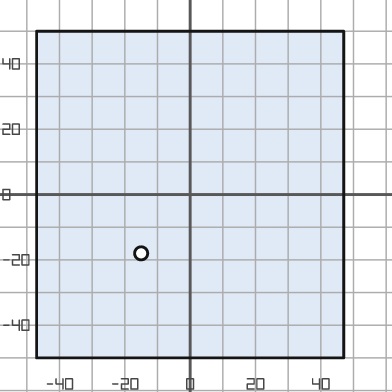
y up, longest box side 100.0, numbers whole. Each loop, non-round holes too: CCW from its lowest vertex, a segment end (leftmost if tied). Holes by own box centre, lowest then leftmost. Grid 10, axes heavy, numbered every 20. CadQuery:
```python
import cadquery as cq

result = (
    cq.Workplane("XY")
    .moveTo(-47.0, -50.0)
    .lineTo(47.0, -50.0)
    .lineTo(47.0, 50.0)
    .lineTo(-47.0, 50.0)
    .close()
    .moveTo(-15.0, -18.0)
    .circle(2.0)
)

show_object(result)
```